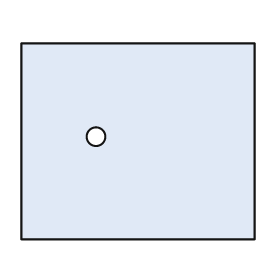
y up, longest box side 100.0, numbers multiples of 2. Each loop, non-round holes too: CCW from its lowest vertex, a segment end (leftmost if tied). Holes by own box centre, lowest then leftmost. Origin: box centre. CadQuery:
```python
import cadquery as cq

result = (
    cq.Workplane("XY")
    .moveTo(-50.0, -42.0)
    .lineTo(50.0, -42.0)
    .lineTo(50.0, 42.0)
    .lineTo(-50.0, 42.0)
    .close()
    .moveTo(-18.0, 2.0)
    .circle(4.0)
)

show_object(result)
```